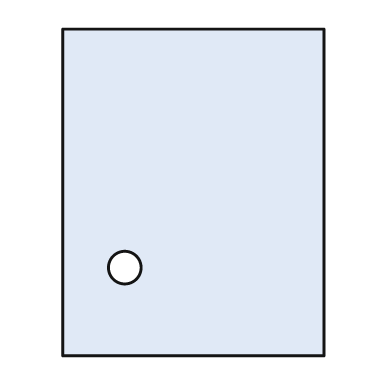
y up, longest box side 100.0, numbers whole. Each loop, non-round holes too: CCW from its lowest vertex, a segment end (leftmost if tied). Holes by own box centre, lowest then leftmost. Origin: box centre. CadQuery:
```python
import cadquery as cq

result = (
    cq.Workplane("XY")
    .moveTo(-40.0, -50.0)
    .lineTo(40.0, -50.0)
    .lineTo(40.0, 50.0)
    .lineTo(-40.0, 50.0)
    .close()
    .moveTo(-21.0, -23.0)
    .circle(5.0)
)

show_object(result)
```